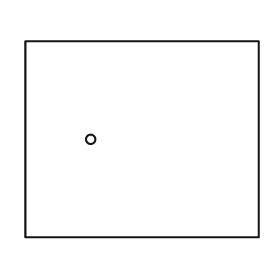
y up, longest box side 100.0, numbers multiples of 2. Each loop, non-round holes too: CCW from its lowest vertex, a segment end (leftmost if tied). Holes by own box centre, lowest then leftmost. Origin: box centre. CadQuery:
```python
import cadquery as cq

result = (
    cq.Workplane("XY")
    .moveTo(-50.0, -42.0)
    .lineTo(50.0, -42.0)
    .lineTo(50.0, 42.0)
    .lineTo(-50.0, 42.0)
    .close()
    .moveTo(-22.0, 0.0)
    .circle(2.0)
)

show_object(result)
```